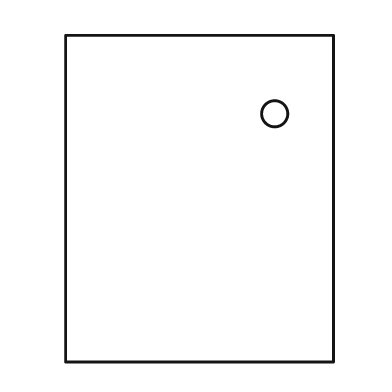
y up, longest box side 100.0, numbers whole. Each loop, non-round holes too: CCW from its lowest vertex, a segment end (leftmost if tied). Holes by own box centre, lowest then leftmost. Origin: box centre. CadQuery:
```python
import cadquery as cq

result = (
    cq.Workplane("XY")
    .moveTo(-41.0, -50.0)
    .lineTo(41.0, -50.0)
    .lineTo(41.0, 50.0)
    .lineTo(-41.0, 50.0)
    .close()
    .moveTo(23.0, 26.0)
    .circle(4.0)
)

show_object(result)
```